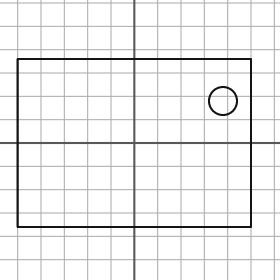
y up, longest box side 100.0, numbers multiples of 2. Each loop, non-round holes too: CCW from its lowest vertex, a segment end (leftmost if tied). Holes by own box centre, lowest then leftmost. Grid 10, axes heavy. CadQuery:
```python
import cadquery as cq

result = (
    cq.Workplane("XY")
    .moveTo(-50.0, -36.0)
    .lineTo(50.0, -36.0)
    .lineTo(50.0, 36.0)
    .lineTo(-50.0, 36.0)
    .close()
    .moveTo(38.0, 18.0)
    .circle(6.0)
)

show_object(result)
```